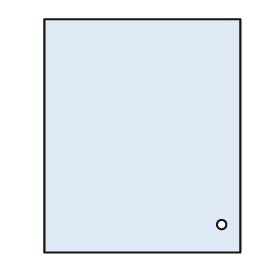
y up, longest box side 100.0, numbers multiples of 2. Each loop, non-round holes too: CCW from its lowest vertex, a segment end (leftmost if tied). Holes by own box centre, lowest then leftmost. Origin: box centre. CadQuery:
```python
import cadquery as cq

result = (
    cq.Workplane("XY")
    .moveTo(-42.0, -50.0)
    .lineTo(42.0, -50.0)
    .lineTo(42.0, 50.0)
    .lineTo(-42.0, 50.0)
    .close()
    .moveTo(34.0, -38.0)
    .circle(2.0)
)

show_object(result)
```